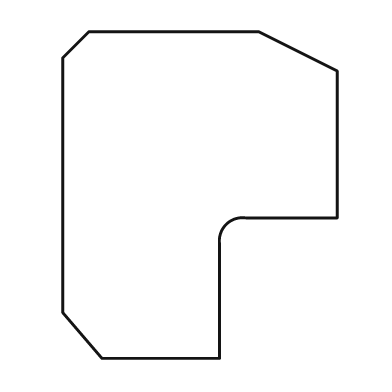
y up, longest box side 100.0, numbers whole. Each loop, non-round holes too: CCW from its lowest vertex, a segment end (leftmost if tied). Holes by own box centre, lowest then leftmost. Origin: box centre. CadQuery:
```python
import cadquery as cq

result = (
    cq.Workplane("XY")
    .moveTo(-30.0, -50.0)
    .lineTo(6.0, -50.0)
    .lineTo(6.0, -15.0)
    .threePointArc((8.0, -9.0), (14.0, -7.0))
    .lineTo(42.0, -7.0)
    .lineTo(42.0, 38.0)
    .lineTo(18.0, 50.0)
    .lineTo(-34.0, 50.0)
    .lineTo(-42.0, 42.0)
    .lineTo(-42.0, -36.0)
    .close()
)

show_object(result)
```